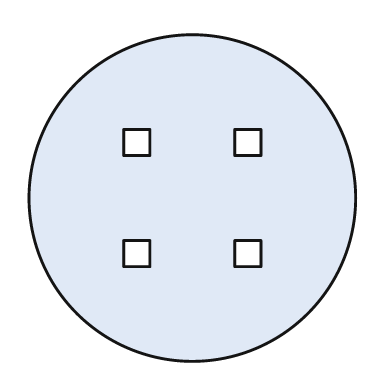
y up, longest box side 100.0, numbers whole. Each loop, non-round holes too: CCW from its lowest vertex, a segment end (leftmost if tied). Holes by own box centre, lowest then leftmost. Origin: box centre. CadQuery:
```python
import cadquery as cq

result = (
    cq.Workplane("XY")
    .moveTo(0.0, 0.0)
    .circle(50.0)
    .moveTo(-21.0, -21.0)
    .lineTo(-13.0, -21.0)
    .lineTo(-13.0, -13.0)
    .lineTo(-21.0, -13.0)
    .close()
    .moveTo(13.0, -21.0)
    .lineTo(21.0, -21.0)
    .lineTo(21.0, -13.0)
    .lineTo(13.0, -13.0)
    .close()
    .moveTo(-21.0, 13.0)
    .lineTo(-13.0, 13.0)
    .lineTo(-13.0, 21.0)
    .lineTo(-21.0, 21.0)
    .close()
    .moveTo(13.0, 13.0)
    .lineTo(21.0, 13.0)
    .lineTo(21.0, 21.0)
    .lineTo(13.0, 21.0)
    .close()
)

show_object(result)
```